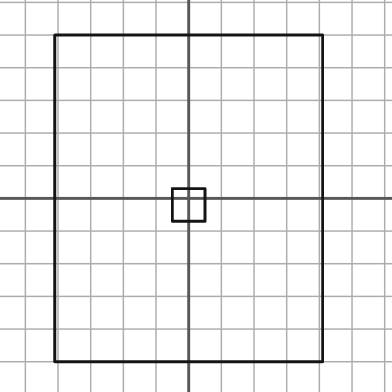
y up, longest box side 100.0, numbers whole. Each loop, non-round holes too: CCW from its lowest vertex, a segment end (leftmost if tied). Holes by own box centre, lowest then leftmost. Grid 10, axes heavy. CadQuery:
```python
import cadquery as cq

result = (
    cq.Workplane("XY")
    .moveTo(-41.0, -50.0)
    .lineTo(41.0, -50.0)
    .lineTo(41.0, 50.0)
    .lineTo(-41.0, 50.0)
    .close()
    .moveTo(-5.0, -7.0)
    .lineTo(5.0, -7.0)
    .lineTo(5.0, 3.0)
    .lineTo(-5.0, 3.0)
    .close()
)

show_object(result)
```